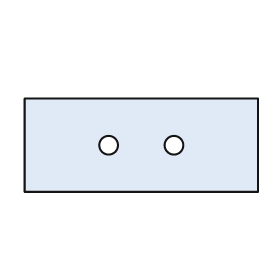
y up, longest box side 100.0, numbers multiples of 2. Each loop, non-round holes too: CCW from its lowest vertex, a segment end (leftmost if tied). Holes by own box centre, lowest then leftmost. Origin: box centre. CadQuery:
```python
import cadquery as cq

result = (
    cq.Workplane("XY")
    .moveTo(-50.0, -20.0)
    .lineTo(50.0, -20.0)
    .lineTo(50.0, 20.0)
    .lineTo(-50.0, 20.0)
    .close()
    .moveTo(-14.0, 0.0)
    .circle(4.0)
    .moveTo(14.0, 0.0)
    .circle(4.0)
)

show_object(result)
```